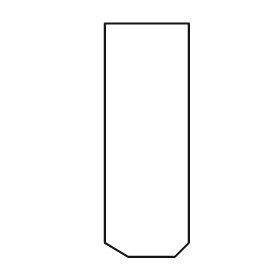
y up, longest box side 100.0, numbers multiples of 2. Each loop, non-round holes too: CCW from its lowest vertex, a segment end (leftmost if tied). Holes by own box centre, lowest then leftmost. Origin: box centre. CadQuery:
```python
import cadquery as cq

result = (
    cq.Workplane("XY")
    .moveTo(-8.0, -50.0)
    .lineTo(12.0, -50.0)
    .lineTo(18.0, -44.0)
    .lineTo(18.0, 50.0)
    .lineTo(-18.0, 50.0)
    .lineTo(-18.0, -44.0)
    .close()
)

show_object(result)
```